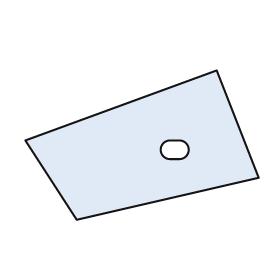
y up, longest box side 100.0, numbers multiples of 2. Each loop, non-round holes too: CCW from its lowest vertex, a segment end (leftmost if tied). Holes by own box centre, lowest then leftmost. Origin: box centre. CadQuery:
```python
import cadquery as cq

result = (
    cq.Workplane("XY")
    .moveTo(-28.0, -32.0)
    .lineTo(50.0, -14.0)
    .lineTo(32.0, 32.0)
    .lineTo(-50.0, 2.0)
    .close()
    .moveTo(12.0, -6.0)
    .lineTo(16.0, -6.0)
    .threePointArc((20.0, -2.0), (16.0, 2.0))
    .lineTo(12.0, 2.0)
    .threePointArc((8.0, -2.0), (12.0, -6.0))
    .close()
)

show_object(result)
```